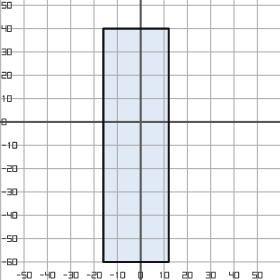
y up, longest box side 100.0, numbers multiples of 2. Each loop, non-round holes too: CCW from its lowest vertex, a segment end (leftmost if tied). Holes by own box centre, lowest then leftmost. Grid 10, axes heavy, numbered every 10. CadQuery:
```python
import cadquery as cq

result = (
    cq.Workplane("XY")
    .moveTo(-16.0, -60.0)
    .lineTo(12.0, -60.0)
    .lineTo(12.0, 40.0)
    .lineTo(-16.0, 40.0)
    .close()
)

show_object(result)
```